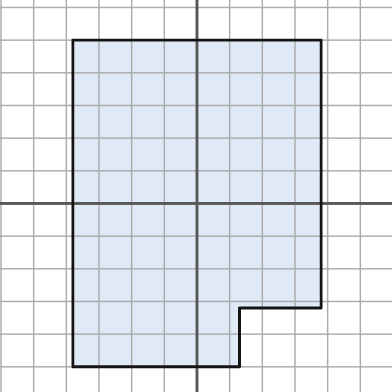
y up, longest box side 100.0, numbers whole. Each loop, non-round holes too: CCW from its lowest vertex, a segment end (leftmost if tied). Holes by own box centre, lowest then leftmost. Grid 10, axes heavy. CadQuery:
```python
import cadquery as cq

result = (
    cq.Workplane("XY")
    .moveTo(-38.0, -50.0)
    .lineTo(13.0, -50.0)
    .lineTo(13.0, -32.0)
    .lineTo(38.0, -32.0)
    .lineTo(38.0, 50.0)
    .lineTo(-38.0, 50.0)
    .close()
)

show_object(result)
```